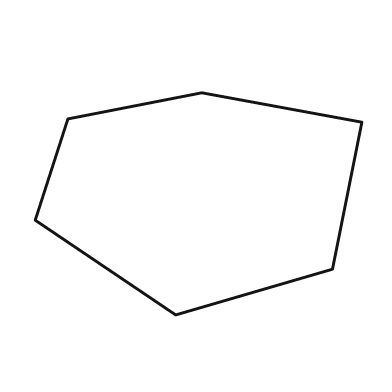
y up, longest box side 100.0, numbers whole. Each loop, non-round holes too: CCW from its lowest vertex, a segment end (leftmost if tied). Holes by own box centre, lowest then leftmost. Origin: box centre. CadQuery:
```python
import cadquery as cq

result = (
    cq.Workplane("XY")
    .moveTo(-7.0, -34.0)
    .lineTo(41.0, -20.0)
    .lineTo(50.0, 25.0)
    .lineTo(1.0, 34.0)
    .lineTo(-40.0, 26.0)
    .lineTo(-50.0, -5.0)
    .close()
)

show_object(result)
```